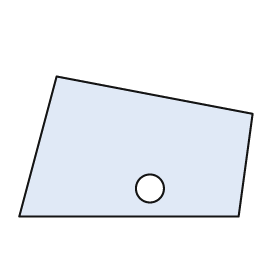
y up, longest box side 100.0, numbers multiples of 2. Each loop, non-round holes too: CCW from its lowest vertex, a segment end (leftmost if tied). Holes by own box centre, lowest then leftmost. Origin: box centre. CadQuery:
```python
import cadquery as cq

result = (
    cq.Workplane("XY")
    .moveTo(-50.0, -30.0)
    .lineTo(44.0, -30.0)
    .lineTo(50.0, 14.0)
    .lineTo(-34.0, 30.0)
    .close()
    .moveTo(6.0, -18.0)
    .circle(6.0)
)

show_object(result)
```